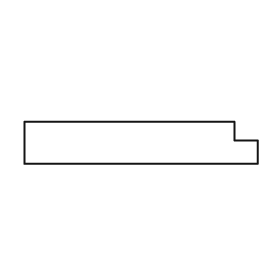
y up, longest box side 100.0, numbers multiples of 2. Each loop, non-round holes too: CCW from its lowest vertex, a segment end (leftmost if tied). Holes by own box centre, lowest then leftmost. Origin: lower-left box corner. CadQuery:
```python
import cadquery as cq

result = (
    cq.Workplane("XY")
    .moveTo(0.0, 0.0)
    .lineTo(100.0, 0.0)
    .lineTo(100.0, 10.0)
    .lineTo(90.0, 10.0)
    .lineTo(90.0, 18.0)
    .lineTo(0.0, 18.0)
    .close()
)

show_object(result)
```